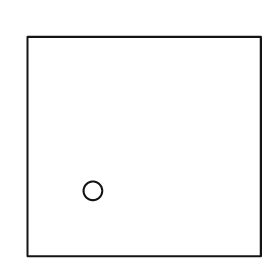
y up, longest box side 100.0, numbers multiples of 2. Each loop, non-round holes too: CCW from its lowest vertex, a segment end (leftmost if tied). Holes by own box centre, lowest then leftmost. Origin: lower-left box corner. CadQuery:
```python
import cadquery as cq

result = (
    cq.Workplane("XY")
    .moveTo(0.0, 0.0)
    .lineTo(100.0, 0.0)
    .lineTo(100.0, 94.0)
    .lineTo(0.0, 94.0)
    .close()
    .moveTo(28.0, 28.0)
    .circle(4.0)
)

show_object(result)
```